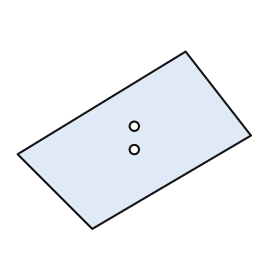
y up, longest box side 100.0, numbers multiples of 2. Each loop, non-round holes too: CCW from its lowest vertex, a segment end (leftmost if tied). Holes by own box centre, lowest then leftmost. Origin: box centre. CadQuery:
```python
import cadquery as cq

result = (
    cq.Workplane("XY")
    .moveTo(-18.0, -38.0)
    .lineTo(50.0, 2.0)
    .lineTo(22.0, 38.0)
    .lineTo(-50.0, -6.0)
    .close()
    .moveTo(0.0, -4.0)
    .circle(2.0)
    .moveTo(0.0, 6.0)
    .circle(2.0)
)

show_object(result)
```